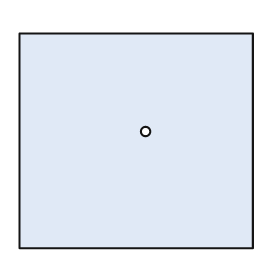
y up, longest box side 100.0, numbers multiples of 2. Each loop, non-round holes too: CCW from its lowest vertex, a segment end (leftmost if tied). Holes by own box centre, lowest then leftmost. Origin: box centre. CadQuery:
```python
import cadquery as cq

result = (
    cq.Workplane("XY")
    .moveTo(-50.0, -46.0)
    .lineTo(50.0, -46.0)
    .lineTo(50.0, 46.0)
    .lineTo(-50.0, 46.0)
    .close()
    .moveTo(4.0, 4.0)
    .circle(2.0)
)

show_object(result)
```